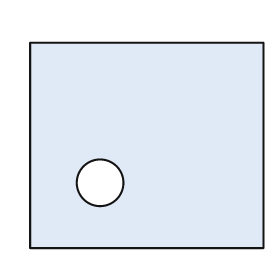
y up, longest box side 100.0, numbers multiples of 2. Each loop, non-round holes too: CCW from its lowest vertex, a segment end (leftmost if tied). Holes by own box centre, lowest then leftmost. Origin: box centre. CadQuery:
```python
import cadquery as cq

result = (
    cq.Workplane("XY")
    .moveTo(-50.0, -44.0)
    .lineTo(50.0, -44.0)
    .lineTo(50.0, 44.0)
    .lineTo(-50.0, 44.0)
    .close()
    .moveTo(-20.0, -16.0)
    .circle(10.0)
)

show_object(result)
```